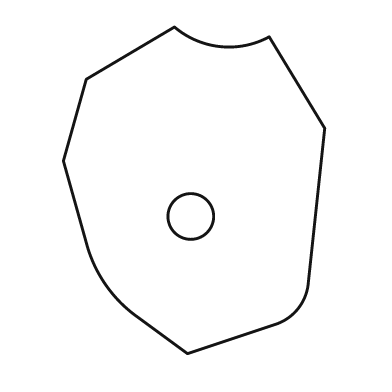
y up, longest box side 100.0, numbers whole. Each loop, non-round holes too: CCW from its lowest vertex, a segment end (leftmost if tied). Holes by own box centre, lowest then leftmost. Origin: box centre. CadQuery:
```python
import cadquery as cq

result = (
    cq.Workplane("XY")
    .moveTo(-2.0, -50.0)
    .lineTo(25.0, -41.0)
    .threePointArc((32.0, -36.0), (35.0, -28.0))
    .lineTo(40.0, 19.0)
    .lineTo(23.0, 47.0)
    .threePointArc((8.0, 44.0), (-6.0, 50.0))
    .lineTo(-33.0, 34.0)
    .lineTo(-40.0, 9.0)
    .lineTo(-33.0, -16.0)
    .threePointArc((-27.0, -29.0), (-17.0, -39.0))
    .close()
    .moveTo(-1.0, -8.0)
    .circle(7.0)
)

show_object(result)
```